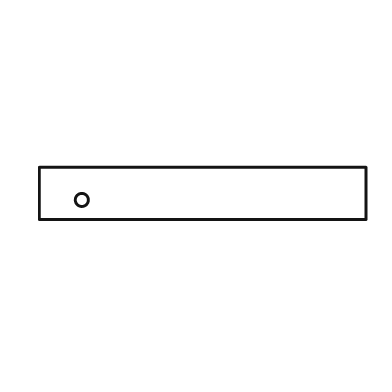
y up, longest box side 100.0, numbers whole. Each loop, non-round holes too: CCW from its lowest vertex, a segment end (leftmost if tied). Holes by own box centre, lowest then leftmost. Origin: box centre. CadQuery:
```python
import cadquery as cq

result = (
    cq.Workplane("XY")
    .moveTo(-50.0, -8.0)
    .lineTo(50.0, -8.0)
    .lineTo(50.0, 8.0)
    .lineTo(-50.0, 8.0)
    .close()
    .moveTo(-37.0, -2.0)
    .circle(2.0)
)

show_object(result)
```